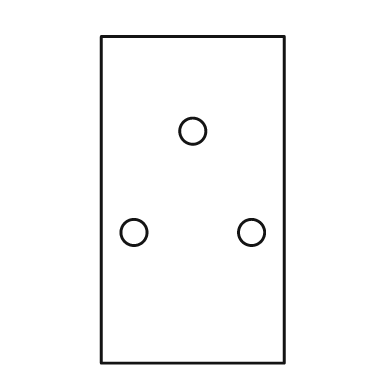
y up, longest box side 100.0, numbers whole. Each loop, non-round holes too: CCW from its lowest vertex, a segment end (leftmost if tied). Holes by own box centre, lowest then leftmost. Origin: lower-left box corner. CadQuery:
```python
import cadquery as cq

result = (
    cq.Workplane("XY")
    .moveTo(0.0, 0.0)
    .lineTo(56.0, 0.0)
    .lineTo(56.0, 100.0)
    .lineTo(0.0, 100.0)
    .close()
    .moveTo(10.0, 40.0)
    .circle(4.0)
    .moveTo(46.0, 40.0)
    .circle(4.0)
    .moveTo(28.0, 71.0)
    .circle(4.0)
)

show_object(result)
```